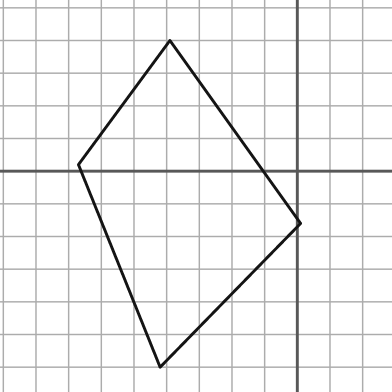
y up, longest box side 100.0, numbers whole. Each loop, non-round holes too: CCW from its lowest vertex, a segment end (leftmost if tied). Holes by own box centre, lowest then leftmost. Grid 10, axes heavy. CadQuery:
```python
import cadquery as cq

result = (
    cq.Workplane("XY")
    .moveTo(-42.0, -60.0)
    .lineTo(1.0, -16.0)
    .lineTo(-39.0, 40.0)
    .lineTo(-67.0, 2.0)
    .close()
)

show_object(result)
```